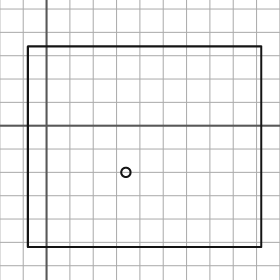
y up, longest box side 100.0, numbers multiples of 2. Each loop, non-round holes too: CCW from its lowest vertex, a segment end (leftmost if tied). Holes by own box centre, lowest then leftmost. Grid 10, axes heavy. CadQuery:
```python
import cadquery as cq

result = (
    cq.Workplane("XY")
    .moveTo(-8.0, -52.0)
    .lineTo(92.0, -52.0)
    .lineTo(92.0, 34.0)
    .lineTo(-8.0, 34.0)
    .close()
    .moveTo(34.0, -20.0)
    .circle(2.0)
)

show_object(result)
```